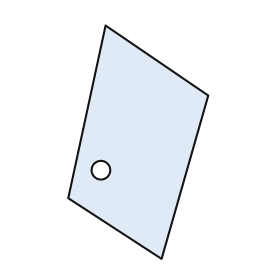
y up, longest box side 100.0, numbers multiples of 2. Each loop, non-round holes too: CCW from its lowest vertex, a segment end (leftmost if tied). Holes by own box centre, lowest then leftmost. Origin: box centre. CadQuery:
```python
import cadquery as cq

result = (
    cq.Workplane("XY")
    .moveTo(10.0, -50.0)
    .lineTo(30.0, 20.0)
    .lineTo(-14.0, 50.0)
    .lineTo(-30.0, -24.0)
    .close()
    .moveTo(-16.0, -12.0)
    .circle(4.0)
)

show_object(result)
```